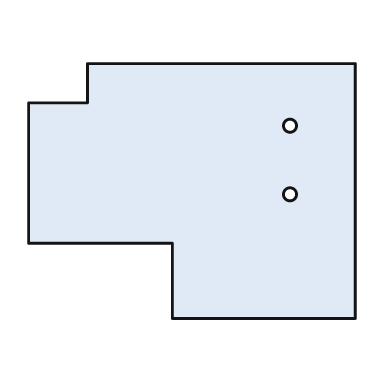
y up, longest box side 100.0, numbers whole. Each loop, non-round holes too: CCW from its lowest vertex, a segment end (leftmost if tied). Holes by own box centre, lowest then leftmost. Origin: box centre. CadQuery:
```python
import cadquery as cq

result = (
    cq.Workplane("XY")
    .moveTo(-6.0, -39.0)
    .lineTo(50.0, -39.0)
    .lineTo(50.0, 39.0)
    .lineTo(-32.0, 39.0)
    .lineTo(-32.0, 27.0)
    .lineTo(-50.0, 27.0)
    .lineTo(-50.0, -16.0)
    .lineTo(-6.0, -16.0)
    .close()
    .moveTo(30.0, -1.0)
    .circle(2.0)
    .moveTo(30.0, 20.0)
    .circle(2.0)
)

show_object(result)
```